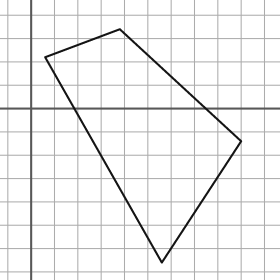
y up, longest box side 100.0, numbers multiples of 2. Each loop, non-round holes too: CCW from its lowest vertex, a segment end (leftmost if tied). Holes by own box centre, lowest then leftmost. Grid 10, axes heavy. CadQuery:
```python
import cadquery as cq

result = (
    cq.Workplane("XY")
    .moveTo(56.0, -66.0)
    .lineTo(90.0, -14.0)
    .lineTo(38.0, 34.0)
    .lineTo(6.0, 22.0)
    .close()
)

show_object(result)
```